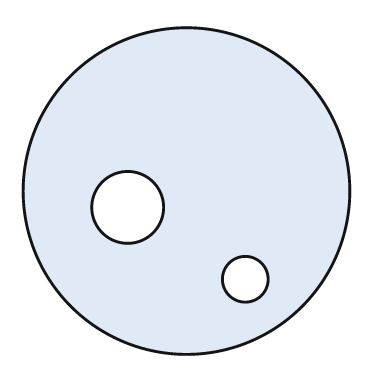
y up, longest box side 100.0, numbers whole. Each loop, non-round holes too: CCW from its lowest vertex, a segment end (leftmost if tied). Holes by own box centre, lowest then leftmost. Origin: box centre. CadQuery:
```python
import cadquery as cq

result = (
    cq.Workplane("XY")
    .moveTo(0.0, 0.0)
    .circle(50.0)
    .moveTo(18.0, -27.0)
    .circle(7.0)
    .moveTo(-18.0, -5.0)
    .circle(11.0)
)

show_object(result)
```